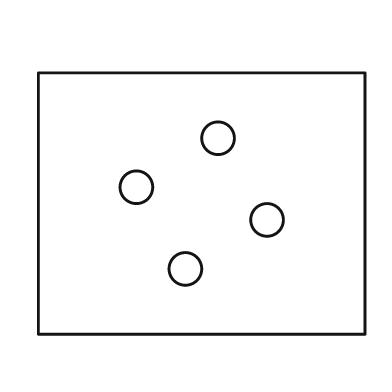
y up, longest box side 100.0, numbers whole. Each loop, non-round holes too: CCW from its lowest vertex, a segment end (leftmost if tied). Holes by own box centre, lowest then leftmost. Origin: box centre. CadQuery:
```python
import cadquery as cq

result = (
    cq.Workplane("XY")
    .moveTo(-50.0, -40.0)
    .lineTo(50.0, -40.0)
    .lineTo(50.0, 40.0)
    .lineTo(-50.0, 40.0)
    .close()
    .moveTo(-5.0, -20.0)
    .circle(5.0)
    .moveTo(20.0, -5.0)
    .circle(5.0)
    .moveTo(-20.0, 5.0)
    .circle(5.0)
    .moveTo(5.0, 20.0)
    .circle(5.0)
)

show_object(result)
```